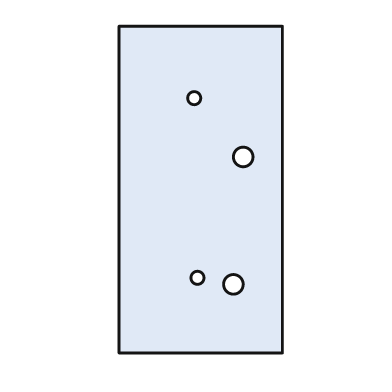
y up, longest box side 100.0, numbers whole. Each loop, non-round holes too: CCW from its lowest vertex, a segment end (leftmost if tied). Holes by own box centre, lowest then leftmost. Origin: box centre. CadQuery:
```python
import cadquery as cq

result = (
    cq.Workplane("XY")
    .moveTo(-25.0, -50.0)
    .lineTo(25.0, -50.0)
    .lineTo(25.0, 50.0)
    .lineTo(-25.0, 50.0)
    .close()
    .moveTo(10.0, -29.0)
    .circle(3.0)
    .moveTo(-1.0, -27.0)
    .circle(2.0)
    .moveTo(13.0, 10.0)
    .circle(3.0)
    .moveTo(-2.0, 28.0)
    .circle(2.0)
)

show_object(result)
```